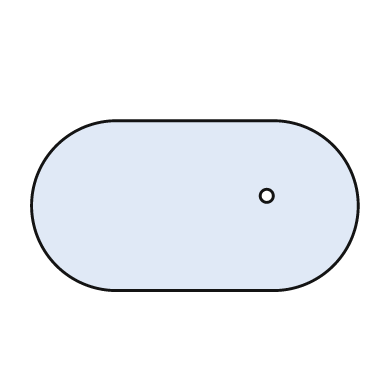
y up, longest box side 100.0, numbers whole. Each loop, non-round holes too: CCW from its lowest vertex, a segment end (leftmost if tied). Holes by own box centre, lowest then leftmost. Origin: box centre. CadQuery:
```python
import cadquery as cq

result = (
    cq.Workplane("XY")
    .moveTo(-24.0, -26.0)
    .lineTo(24.0, -26.0)
    .threePointArc((50.0, 0.0), (24.0, 26.0))
    .lineTo(-24.0, 26.0)
    .threePointArc((-50.0, 0.0), (-24.0, -26.0))
    .close()
    .moveTo(22.0, 3.0)
    .circle(2.0)
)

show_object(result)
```